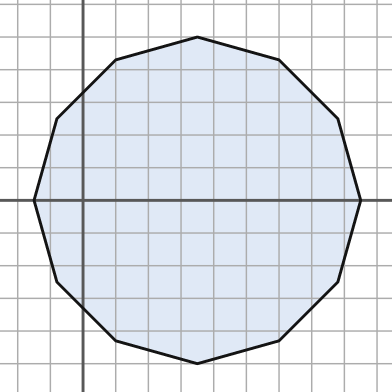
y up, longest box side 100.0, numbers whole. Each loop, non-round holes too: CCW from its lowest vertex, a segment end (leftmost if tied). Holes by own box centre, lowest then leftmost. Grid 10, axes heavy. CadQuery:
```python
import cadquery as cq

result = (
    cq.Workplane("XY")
    .moveTo(35.0, -50.0)
    .lineTo(60.0, -43.0)
    .lineTo(78.0, -25.0)
    .lineTo(85.0, 0.0)
    .lineTo(78.0, 25.0)
    .lineTo(60.0, 43.0)
    .lineTo(35.0, 50.0)
    .lineTo(10.0, 43.0)
    .lineTo(-8.0, 25.0)
    .lineTo(-15.0, 0.0)
    .lineTo(-8.0, -25.0)
    .lineTo(10.0, -43.0)
    .close()
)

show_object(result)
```